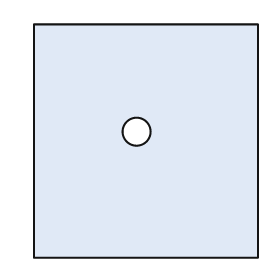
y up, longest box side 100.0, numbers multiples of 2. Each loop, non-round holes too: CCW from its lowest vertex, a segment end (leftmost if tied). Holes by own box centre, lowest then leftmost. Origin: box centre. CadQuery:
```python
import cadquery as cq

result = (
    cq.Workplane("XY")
    .moveTo(-48.0, -50.0)
    .lineTo(48.0, -50.0)
    .lineTo(48.0, 50.0)
    .lineTo(-48.0, 50.0)
    .close()
    .moveTo(-4.0, 4.0)
    .circle(6.0)
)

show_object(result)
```